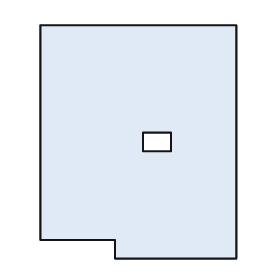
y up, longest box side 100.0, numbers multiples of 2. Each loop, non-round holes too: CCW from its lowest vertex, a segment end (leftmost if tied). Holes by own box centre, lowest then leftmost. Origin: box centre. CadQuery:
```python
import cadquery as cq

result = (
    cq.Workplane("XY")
    .moveTo(-10.0, -50.0)
    .lineTo(42.0, -50.0)
    .lineTo(42.0, 50.0)
    .lineTo(-42.0, 50.0)
    .lineTo(-42.0, -42.0)
    .lineTo(-10.0, -42.0)
    .close()
    .moveTo(2.0, -4.0)
    .lineTo(14.0, -4.0)
    .lineTo(14.0, 4.0)
    .lineTo(2.0, 4.0)
    .close()
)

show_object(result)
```